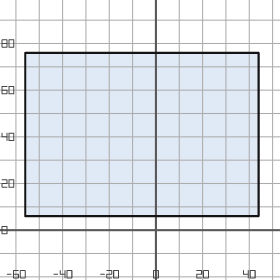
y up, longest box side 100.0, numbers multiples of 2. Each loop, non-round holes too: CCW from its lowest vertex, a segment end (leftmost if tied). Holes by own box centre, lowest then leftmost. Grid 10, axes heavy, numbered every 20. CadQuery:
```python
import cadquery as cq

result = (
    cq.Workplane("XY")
    .moveTo(-56.0, 6.0)
    .lineTo(44.0, 6.0)
    .lineTo(44.0, 76.0)
    .lineTo(-56.0, 76.0)
    .close()
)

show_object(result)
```